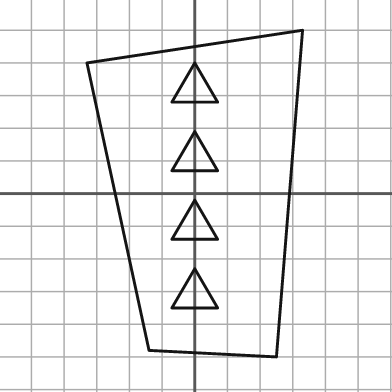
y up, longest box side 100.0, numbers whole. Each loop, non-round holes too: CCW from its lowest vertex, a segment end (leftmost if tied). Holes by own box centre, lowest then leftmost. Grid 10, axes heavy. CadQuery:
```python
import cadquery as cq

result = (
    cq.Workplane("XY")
    .moveTo(25.0, -50.0)
    .lineTo(33.0, 50.0)
    .lineTo(-33.0, 40.0)
    .lineTo(-14.0, -48.0)
    .close()
    .moveTo(-7.0, -35.0)
    .lineTo(7.0, -35.0)
    .lineTo(0.0, -23.0)
    .close()
    .moveTo(-7.0, -14.0)
    .lineTo(7.0, -14.0)
    .lineTo(0.0, -2.0)
    .close()
    .moveTo(-7.0, 7.0)
    .lineTo(7.0, 7.0)
    .lineTo(0.0, 19.0)
    .close()
    .moveTo(-7.0, 28.0)
    .lineTo(7.0, 28.0)
    .lineTo(0.0, 40.0)
    .close()
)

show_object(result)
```